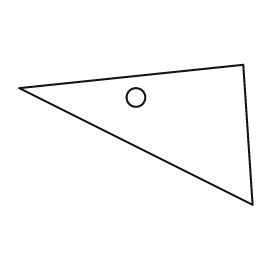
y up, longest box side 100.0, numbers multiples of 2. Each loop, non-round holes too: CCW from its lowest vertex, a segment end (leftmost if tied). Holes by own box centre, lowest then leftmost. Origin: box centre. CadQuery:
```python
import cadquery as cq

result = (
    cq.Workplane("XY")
    .moveTo(50.0, -30.0)
    .lineTo(46.0, 30.0)
    .lineTo(-50.0, 20.0)
    .close()
    .moveTo(0.0, 16.0)
    .circle(4.0)
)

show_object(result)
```